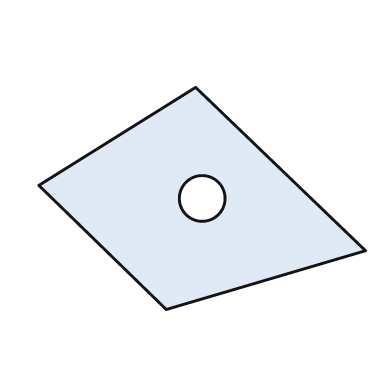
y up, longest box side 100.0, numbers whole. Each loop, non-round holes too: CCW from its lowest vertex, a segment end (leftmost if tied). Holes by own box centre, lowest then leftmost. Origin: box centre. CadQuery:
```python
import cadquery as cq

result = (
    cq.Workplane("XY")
    .moveTo(-11.0, -34.0)
    .lineTo(50.0, -16.0)
    .lineTo(-2.0, 34.0)
    .lineTo(-50.0, 4.0)
    .close()
    .moveTo(0.0, 0.0)
    .circle(7.0)
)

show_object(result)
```